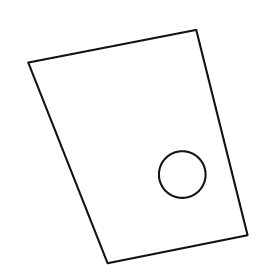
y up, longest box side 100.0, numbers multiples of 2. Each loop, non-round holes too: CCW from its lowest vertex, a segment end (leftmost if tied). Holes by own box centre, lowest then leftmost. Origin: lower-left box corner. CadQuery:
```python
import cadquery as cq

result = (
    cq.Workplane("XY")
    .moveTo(34.0, 0.0)
    .lineTo(94.0, 12.0)
    .lineTo(72.0, 100.0)
    .lineTo(0.0, 86.0)
    .close()
    .moveTo(66.0, 38.0)
    .circle(10.0)
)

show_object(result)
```